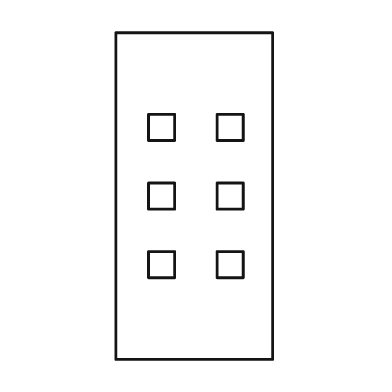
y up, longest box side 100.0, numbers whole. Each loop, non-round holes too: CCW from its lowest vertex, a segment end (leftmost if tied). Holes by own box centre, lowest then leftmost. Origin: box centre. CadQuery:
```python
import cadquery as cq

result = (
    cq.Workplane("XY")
    .moveTo(-24.0, -50.0)
    .lineTo(24.0, -50.0)
    .lineTo(24.0, 50.0)
    .lineTo(-24.0, 50.0)
    .close()
    .moveTo(-14.0, -25.0)
    .lineTo(-6.0, -25.0)
    .lineTo(-6.0, -17.0)
    .lineTo(-14.0, -17.0)
    .close()
    .moveTo(7.0, -25.0)
    .lineTo(15.0, -25.0)
    .lineTo(15.0, -17.0)
    .lineTo(7.0, -17.0)
    .close()
    .moveTo(-14.0, -4.0)
    .lineTo(-6.0, -4.0)
    .lineTo(-6.0, 4.0)
    .lineTo(-14.0, 4.0)
    .close()
    .moveTo(7.0, -4.0)
    .lineTo(15.0, -4.0)
    .lineTo(15.0, 4.0)
    .lineTo(7.0, 4.0)
    .close()
    .moveTo(-14.0, 17.0)
    .lineTo(-6.0, 17.0)
    .lineTo(-6.0, 25.0)
    .lineTo(-14.0, 25.0)
    .close()
    .moveTo(7.0, 17.0)
    .lineTo(15.0, 17.0)
    .lineTo(15.0, 25.0)
    .lineTo(7.0, 25.0)
    .close()
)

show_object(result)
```